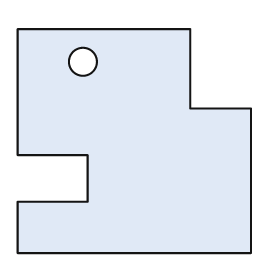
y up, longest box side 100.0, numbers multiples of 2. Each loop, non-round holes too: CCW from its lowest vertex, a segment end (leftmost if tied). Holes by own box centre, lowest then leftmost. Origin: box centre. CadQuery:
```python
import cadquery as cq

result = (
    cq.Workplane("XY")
    .moveTo(-50.0, -48.0)
    .lineTo(50.0, -48.0)
    .lineTo(50.0, 14.0)
    .lineTo(24.0, 14.0)
    .lineTo(24.0, 48.0)
    .lineTo(-50.0, 48.0)
    .lineTo(-50.0, -6.0)
    .lineTo(-20.0, -6.0)
    .lineTo(-20.0, -26.0)
    .lineTo(-50.0, -26.0)
    .close()
    .moveTo(-22.0, 34.0)
    .circle(6.0)
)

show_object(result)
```